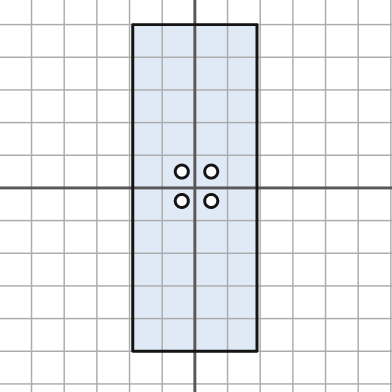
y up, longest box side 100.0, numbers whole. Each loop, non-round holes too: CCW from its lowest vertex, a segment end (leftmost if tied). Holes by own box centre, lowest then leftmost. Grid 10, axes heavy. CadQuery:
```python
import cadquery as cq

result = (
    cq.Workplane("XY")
    .moveTo(-19.0, -50.0)
    .lineTo(19.0, -50.0)
    .lineTo(19.0, 50.0)
    .lineTo(-19.0, 50.0)
    .close()
    .moveTo(-4.0, -4.0)
    .circle(2.0)
    .moveTo(5.0, -4.0)
    .circle(2.0)
    .moveTo(-4.0, 5.0)
    .circle(2.0)
    .moveTo(5.0, 5.0)
    .circle(2.0)
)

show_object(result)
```